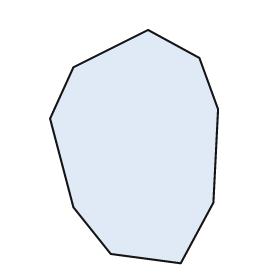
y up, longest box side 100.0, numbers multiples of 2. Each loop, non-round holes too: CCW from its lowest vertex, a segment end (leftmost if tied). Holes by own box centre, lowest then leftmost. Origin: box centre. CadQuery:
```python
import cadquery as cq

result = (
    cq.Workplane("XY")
    .moveTo(20.0, -50.0)
    .lineTo(34.0, -24.0)
    .lineTo(36.0, 16.0)
    .lineTo(28.0, 38.0)
    .lineTo(6.0, 50.0)
    .lineTo(-26.0, 34.0)
    .lineTo(-36.0, 12.0)
    .lineTo(-26.0, -26.0)
    .lineTo(-10.0, -46.0)
    .close()
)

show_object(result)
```